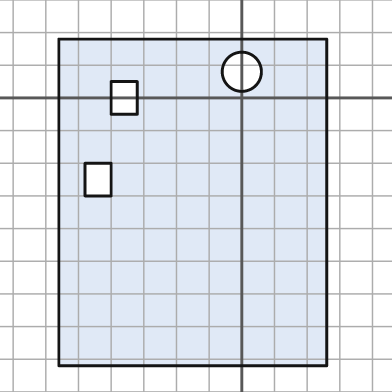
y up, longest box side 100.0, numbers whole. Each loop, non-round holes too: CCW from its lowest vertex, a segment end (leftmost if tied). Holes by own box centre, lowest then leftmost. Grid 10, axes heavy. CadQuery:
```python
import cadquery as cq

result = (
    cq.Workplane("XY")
    .moveTo(-56.0, -82.0)
    .lineTo(26.0, -82.0)
    .lineTo(26.0, 18.0)
    .lineTo(-56.0, 18.0)
    .close()
    .moveTo(-48.0, -30.0)
    .lineTo(-40.0, -30.0)
    .lineTo(-40.0, -20.0)
    .lineTo(-48.0, -20.0)
    .close()
    .moveTo(-40.0, -5.0)
    .lineTo(-32.0, -5.0)
    .lineTo(-32.0, 5.0)
    .lineTo(-40.0, 5.0)
    .close()
    .moveTo(0.0, 8.0)
    .circle(6.0)
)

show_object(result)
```